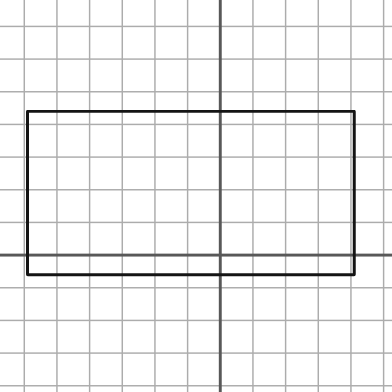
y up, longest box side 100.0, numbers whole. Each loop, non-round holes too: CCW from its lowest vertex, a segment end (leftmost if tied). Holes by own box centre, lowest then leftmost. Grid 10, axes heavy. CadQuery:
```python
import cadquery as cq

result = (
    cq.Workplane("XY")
    .moveTo(-59.0, -6.0)
    .lineTo(41.0, -6.0)
    .lineTo(41.0, 44.0)
    .lineTo(-59.0, 44.0)
    .close()
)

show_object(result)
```